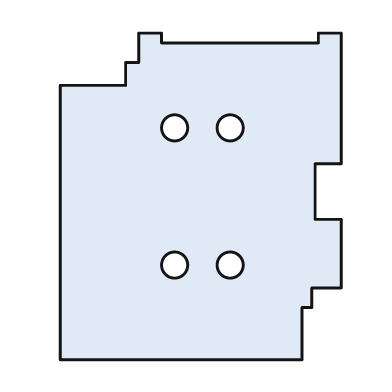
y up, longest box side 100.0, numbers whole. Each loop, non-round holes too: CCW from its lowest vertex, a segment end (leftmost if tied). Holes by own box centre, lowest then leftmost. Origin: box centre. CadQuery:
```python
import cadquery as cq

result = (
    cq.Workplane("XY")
    .moveTo(-43.0, -50.0)
    .lineTo(31.0, -50.0)
    .lineTo(31.0, -34.0)
    .lineTo(34.0, -34.0)
    .lineTo(34.0, -28.0)
    .lineTo(43.0, -28.0)
    .lineTo(43.0, -7.0)
    .lineTo(35.0, -7.0)
    .lineTo(35.0, 10.0)
    .lineTo(43.0, 10.0)
    .lineTo(43.0, 50.0)
    .lineTo(36.0, 50.0)
    .lineTo(36.0, 47.0)
    .lineTo(-12.0, 47.0)
    .lineTo(-12.0, 50.0)
    .lineTo(-19.0, 50.0)
    .lineTo(-19.0, 41.0)
    .lineTo(-23.0, 41.0)
    .lineTo(-23.0, 34.0)
    .lineTo(-43.0, 34.0)
    .close()
    .moveTo(-8.0, -21.0)
    .circle(4.0)
    .moveTo(9.0, -21.0)
    .circle(4.0)
    .moveTo(-8.0, 21.0)
    .circle(4.0)
    .moveTo(9.0, 21.0)
    .circle(4.0)
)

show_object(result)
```